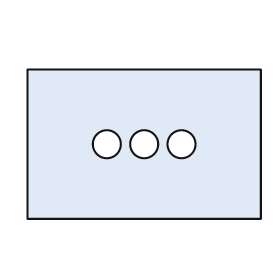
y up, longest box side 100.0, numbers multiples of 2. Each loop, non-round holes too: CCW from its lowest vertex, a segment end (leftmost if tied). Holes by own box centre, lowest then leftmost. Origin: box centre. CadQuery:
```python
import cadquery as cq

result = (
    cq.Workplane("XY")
    .moveTo(-50.0, -32.0)
    .lineTo(50.0, -32.0)
    .lineTo(50.0, 32.0)
    .lineTo(-50.0, 32.0)
    .close()
    .moveTo(-16.0, 0.0)
    .circle(6.0)
    .moveTo(0.0, 0.0)
    .circle(6.0)
    .moveTo(16.0, 0.0)
    .circle(6.0)
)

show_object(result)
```